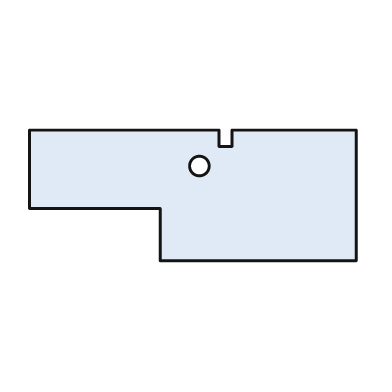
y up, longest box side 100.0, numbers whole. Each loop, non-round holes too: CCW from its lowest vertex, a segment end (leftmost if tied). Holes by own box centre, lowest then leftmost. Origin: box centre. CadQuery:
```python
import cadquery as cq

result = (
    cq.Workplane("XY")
    .moveTo(-10.0, -20.0)
    .lineTo(50.0, -20.0)
    .lineTo(50.0, 20.0)
    .lineTo(12.0, 20.0)
    .lineTo(12.0, 15.0)
    .lineTo(8.0, 15.0)
    .lineTo(8.0, 20.0)
    .lineTo(-50.0, 20.0)
    .lineTo(-50.0, -4.0)
    .lineTo(-10.0, -4.0)
    .close()
    .moveTo(2.0, 9.0)
    .circle(3.0)
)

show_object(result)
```